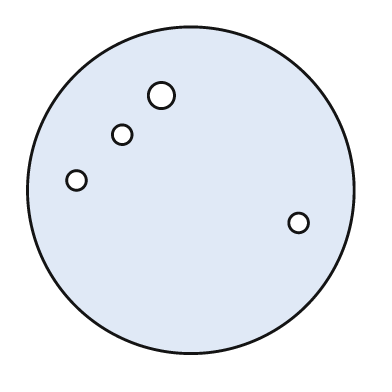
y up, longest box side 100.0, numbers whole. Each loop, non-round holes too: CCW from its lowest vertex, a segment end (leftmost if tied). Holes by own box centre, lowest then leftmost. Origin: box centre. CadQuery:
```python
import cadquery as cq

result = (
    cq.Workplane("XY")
    .moveTo(0.0, 0.0)
    .circle(50.0)
    .moveTo(33.0, -10.0)
    .circle(3.0)
    .moveTo(-35.0, 3.0)
    .circle(3.0)
    .moveTo(-21.0, 17.0)
    .circle(3.0)
    .moveTo(-9.0, 29.0)
    .circle(4.0)
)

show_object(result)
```